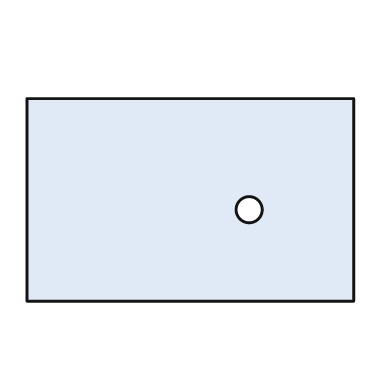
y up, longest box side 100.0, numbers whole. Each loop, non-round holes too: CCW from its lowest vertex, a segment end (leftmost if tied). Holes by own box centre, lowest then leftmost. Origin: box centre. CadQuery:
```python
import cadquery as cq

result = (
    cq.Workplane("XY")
    .moveTo(-50.0, -31.0)
    .lineTo(50.0, -31.0)
    .lineTo(50.0, 31.0)
    .lineTo(-50.0, 31.0)
    .close()
    .moveTo(18.0, -3.0)
    .circle(4.0)
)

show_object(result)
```